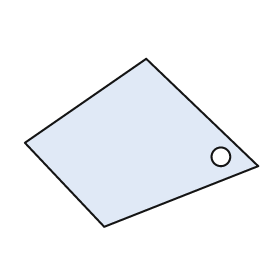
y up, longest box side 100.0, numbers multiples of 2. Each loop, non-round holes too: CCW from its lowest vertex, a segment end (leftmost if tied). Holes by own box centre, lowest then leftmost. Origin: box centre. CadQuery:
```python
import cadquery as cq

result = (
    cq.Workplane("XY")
    .moveTo(-16.0, -36.0)
    .lineTo(50.0, -10.0)
    .lineTo(2.0, 36.0)
    .lineTo(-50.0, 0.0)
    .close()
    .moveTo(34.0, -6.0)
    .circle(4.0)
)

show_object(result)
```